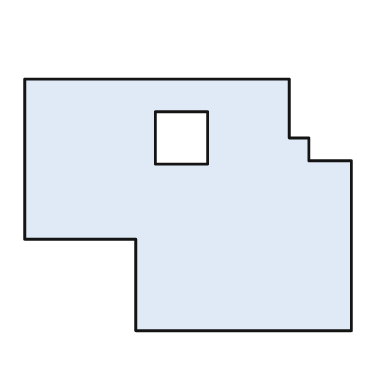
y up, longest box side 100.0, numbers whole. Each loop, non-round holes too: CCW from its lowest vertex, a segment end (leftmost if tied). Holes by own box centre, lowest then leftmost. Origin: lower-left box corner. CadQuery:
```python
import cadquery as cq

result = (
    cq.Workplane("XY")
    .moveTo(34.0, 0.0)
    .lineTo(100.0, 0.0)
    .lineTo(100.0, 52.0)
    .lineTo(87.0, 52.0)
    .lineTo(87.0, 59.0)
    .lineTo(81.0, 59.0)
    .lineTo(81.0, 77.0)
    .lineTo(0.0, 77.0)
    .lineTo(0.0, 28.0)
    .lineTo(34.0, 28.0)
    .close()
    .moveTo(40.0, 51.0)
    .lineTo(56.0, 51.0)
    .lineTo(56.0, 67.0)
    .lineTo(40.0, 67.0)
    .close()
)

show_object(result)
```